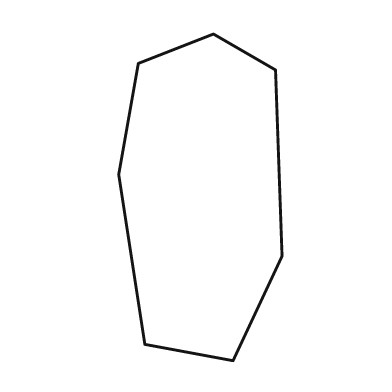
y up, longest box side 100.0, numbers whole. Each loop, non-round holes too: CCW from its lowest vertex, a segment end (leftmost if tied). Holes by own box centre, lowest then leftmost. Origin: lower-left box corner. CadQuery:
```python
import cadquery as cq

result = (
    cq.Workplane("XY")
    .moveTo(35.0, 0.0)
    .lineTo(50.0, 32.0)
    .lineTo(48.0, 89.0)
    .lineTo(29.0, 100.0)
    .lineTo(6.0, 91.0)
    .lineTo(0.0, 57.0)
    .lineTo(8.0, 5.0)
    .close()
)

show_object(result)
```